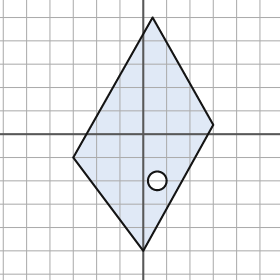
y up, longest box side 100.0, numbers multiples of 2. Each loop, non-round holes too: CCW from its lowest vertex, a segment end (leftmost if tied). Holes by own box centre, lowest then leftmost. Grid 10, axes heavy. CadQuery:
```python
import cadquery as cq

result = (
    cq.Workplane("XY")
    .moveTo(0.0, -50.0)
    .lineTo(30.0, 4.0)
    .lineTo(4.0, 50.0)
    .lineTo(-30.0, -10.0)
    .close()
    .moveTo(6.0, -20.0)
    .circle(4.0)
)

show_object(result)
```